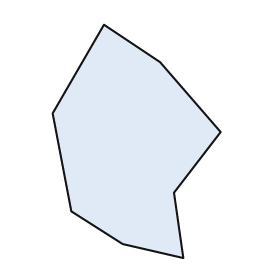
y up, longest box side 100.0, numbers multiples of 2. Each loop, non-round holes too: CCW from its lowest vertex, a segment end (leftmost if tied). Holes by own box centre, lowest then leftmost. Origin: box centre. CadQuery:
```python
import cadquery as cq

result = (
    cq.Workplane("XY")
    .moveTo(20.0, -50.0)
    .lineTo(16.0, -22.0)
    .lineTo(36.0, 4.0)
    .lineTo(10.0, 34.0)
    .lineTo(-14.0, 50.0)
    .lineTo(-36.0, 12.0)
    .lineTo(-28.0, -30.0)
    .lineTo(-6.0, -44.0)
    .close()
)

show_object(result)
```